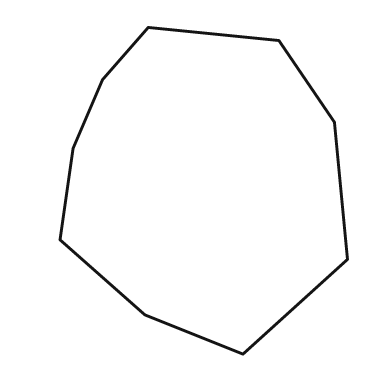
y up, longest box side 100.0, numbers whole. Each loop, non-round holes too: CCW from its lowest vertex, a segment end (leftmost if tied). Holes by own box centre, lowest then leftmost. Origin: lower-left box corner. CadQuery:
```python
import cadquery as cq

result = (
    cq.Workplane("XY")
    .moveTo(56.0, 0.0)
    .lineTo(88.0, 29.0)
    .lineTo(84.0, 71.0)
    .lineTo(67.0, 96.0)
    .lineTo(27.0, 100.0)
    .lineTo(13.0, 84.0)
    .lineTo(4.0, 63.0)
    .lineTo(0.0, 35.0)
    .lineTo(26.0, 12.0)
    .close()
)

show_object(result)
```